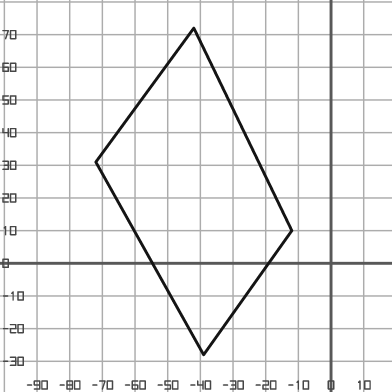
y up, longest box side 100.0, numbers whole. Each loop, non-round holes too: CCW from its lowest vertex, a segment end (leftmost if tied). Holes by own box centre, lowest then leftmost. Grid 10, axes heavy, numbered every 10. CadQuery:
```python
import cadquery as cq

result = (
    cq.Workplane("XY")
    .moveTo(-39.0, -28.0)
    .lineTo(-12.0, 10.0)
    .lineTo(-42.0, 72.0)
    .lineTo(-72.0, 31.0)
    .close()
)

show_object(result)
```